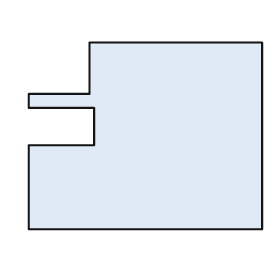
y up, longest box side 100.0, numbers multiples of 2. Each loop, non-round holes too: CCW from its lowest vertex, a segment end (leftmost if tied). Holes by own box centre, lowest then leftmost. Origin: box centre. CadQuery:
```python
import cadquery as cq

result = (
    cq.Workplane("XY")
    .moveTo(-50.0, -40.0)
    .lineTo(50.0, -40.0)
    .lineTo(50.0, 40.0)
    .lineTo(-24.0, 40.0)
    .lineTo(-24.0, 18.0)
    .lineTo(-50.0, 18.0)
    .lineTo(-50.0, 12.0)
    .lineTo(-22.0, 12.0)
    .lineTo(-22.0, -4.0)
    .lineTo(-50.0, -4.0)
    .close()
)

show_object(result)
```